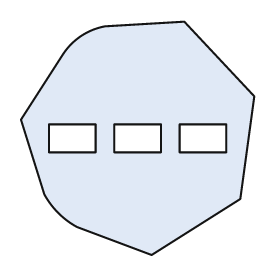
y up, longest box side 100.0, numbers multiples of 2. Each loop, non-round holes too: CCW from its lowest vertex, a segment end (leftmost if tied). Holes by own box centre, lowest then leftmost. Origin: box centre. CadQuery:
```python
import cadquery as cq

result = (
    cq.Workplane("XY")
    .moveTo(6.0, -50.0)
    .lineTo(44.0, -26.0)
    .lineTo(50.0, 18.0)
    .lineTo(20.0, 50.0)
    .lineTo(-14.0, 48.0)
    .threePointArc((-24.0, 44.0), (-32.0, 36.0))
    .lineTo(-50.0, 8.0)
    .lineTo(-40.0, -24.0)
    .threePointArc((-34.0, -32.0), (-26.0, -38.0))
    .close()
    .moveTo(-38.0, -6.0)
    .lineTo(-18.0, -6.0)
    .lineTo(-18.0, 6.0)
    .lineTo(-38.0, 6.0)
    .close()
    .moveTo(-10.0, -6.0)
    .lineTo(10.0, -6.0)
    .lineTo(10.0, 6.0)
    .lineTo(-10.0, 6.0)
    .close()
    .moveTo(18.0, -6.0)
    .lineTo(38.0, -6.0)
    .lineTo(38.0, 6.0)
    .lineTo(18.0, 6.0)
    .close()
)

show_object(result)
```